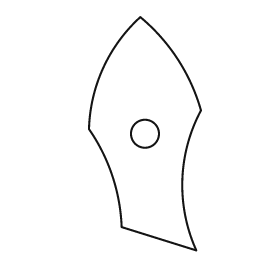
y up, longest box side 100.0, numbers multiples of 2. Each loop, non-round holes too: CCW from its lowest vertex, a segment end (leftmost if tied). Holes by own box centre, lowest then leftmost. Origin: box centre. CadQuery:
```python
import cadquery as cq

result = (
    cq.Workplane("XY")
    .moveTo(22.0, -50.0)
    .threePointArc((16.0, -20.0), (24.0, 10.0))
    .threePointArc((14.0, 32.0), (-2.0, 50.0))
    .threePointArc((-18.0, 28.0), (-24.0, 2.0))
    .threePointArc((-14.0, -18.0), (-10.0, -40.0))
    .close()
    .moveTo(0.0, 0.0)
    .circle(6.0)
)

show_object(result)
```